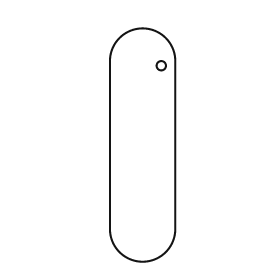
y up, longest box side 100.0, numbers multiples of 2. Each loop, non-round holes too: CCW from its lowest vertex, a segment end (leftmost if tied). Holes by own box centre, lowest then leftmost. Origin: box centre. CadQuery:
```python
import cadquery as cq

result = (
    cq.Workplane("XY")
    .moveTo(-14.0, -36.0)
    .threePointArc((0.0, -50.0), (14.0, -36.0))
    .lineTo(14.0, 36.0)
    .threePointArc((0.0, 50.0), (-14.0, 36.0))
    .close()
    .moveTo(8.0, 34.0)
    .circle(2.0)
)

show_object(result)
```